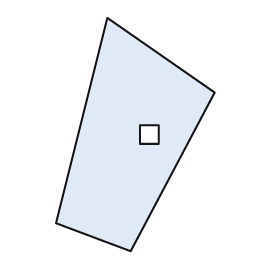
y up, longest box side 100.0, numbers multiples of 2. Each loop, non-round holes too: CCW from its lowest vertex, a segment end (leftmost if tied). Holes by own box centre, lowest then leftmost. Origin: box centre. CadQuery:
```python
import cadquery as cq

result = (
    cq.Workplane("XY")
    .moveTo(-2.0, -50.0)
    .lineTo(34.0, 18.0)
    .lineTo(-12.0, 50.0)
    .lineTo(-34.0, -38.0)
    .close()
    .moveTo(2.0, -4.0)
    .lineTo(10.0, -4.0)
    .lineTo(10.0, 4.0)
    .lineTo(2.0, 4.0)
    .close()
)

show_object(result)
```